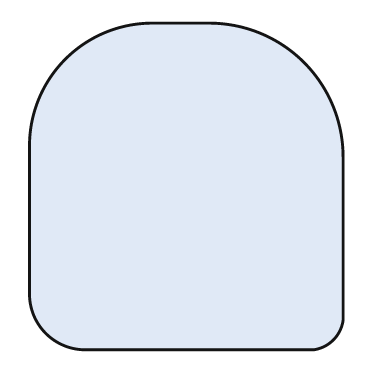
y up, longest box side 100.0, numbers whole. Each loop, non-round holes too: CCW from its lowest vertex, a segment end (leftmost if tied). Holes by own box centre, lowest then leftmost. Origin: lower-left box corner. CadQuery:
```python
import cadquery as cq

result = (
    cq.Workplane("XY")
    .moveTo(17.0, 0.0)
    .lineTo(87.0, 0.0)
    .threePointArc((93.0, 3.0), (96.0, 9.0))
    .lineTo(96.0, 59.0)
    .threePointArc((84.0, 88.0), (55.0, 100.0))
    .lineTo(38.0, 100.0)
    .threePointArc((11.0, 89.0), (0.0, 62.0))
    .lineTo(0.0, 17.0)
    .threePointArc((5.0, 5.0), (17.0, 0.0))
    .close()
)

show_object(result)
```